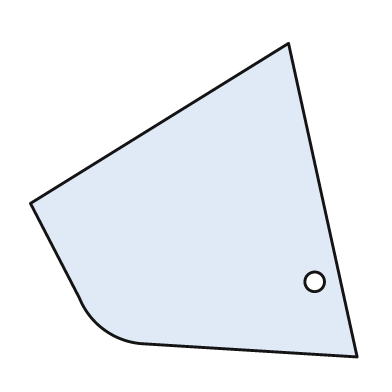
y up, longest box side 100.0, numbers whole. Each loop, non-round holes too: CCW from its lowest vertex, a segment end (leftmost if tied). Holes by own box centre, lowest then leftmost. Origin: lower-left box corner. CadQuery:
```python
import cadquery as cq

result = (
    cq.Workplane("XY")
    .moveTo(100.0, 0.0)
    .lineTo(79.0, 96.0)
    .lineTo(0.0, 47.0)
    .lineTo(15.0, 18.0)
    .threePointArc((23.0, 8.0), (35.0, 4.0))
    .close()
    .moveTo(87.0, 23.0)
    .circle(3.0)
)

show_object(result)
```